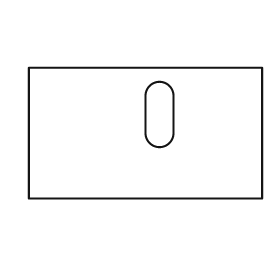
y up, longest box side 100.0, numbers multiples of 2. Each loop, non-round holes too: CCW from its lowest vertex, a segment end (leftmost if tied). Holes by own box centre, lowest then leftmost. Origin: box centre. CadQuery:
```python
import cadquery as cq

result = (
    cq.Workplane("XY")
    .moveTo(-50.0, -28.0)
    .lineTo(50.0, -28.0)
    .lineTo(50.0, 28.0)
    .lineTo(-50.0, 28.0)
    .close()
    .moveTo(0.0, 0.0)
    .threePointArc((6.0, -6.0), (12.0, 0.0))
    .lineTo(12.0, 16.0)
    .threePointArc((6.0, 22.0), (0.0, 16.0))
    .close()
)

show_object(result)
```